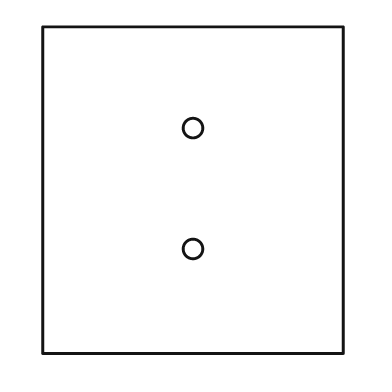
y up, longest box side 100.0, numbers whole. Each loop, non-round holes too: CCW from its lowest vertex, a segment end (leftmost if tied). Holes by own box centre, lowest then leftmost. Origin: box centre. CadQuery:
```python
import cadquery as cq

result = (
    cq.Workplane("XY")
    .moveTo(-46.0, -50.0)
    .lineTo(46.0, -50.0)
    .lineTo(46.0, 50.0)
    .lineTo(-46.0, 50.0)
    .close()
    .moveTo(0.0, -18.0)
    .circle(3.0)
    .moveTo(0.0, 19.0)
    .circle(3.0)
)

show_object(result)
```